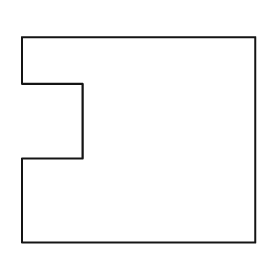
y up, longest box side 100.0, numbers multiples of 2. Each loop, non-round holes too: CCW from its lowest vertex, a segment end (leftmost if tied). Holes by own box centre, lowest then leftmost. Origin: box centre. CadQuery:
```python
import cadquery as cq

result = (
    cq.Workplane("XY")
    .moveTo(-50.0, -44.0)
    .lineTo(50.0, -44.0)
    .lineTo(50.0, 44.0)
    .lineTo(-50.0, 44.0)
    .lineTo(-50.0, 24.0)
    .lineTo(-24.0, 24.0)
    .lineTo(-24.0, -8.0)
    .lineTo(-50.0, -8.0)
    .close()
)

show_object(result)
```